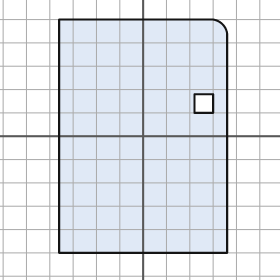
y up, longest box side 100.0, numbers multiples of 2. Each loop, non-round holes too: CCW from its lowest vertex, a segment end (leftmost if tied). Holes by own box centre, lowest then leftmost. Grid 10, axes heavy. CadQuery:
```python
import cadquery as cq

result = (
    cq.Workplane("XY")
    .moveTo(-36.0, -50.0)
    .lineTo(36.0, -50.0)
    .lineTo(36.0, 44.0)
    .threePointArc((34.0, 48.0), (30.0, 50.0))
    .lineTo(-36.0, 50.0)
    .close()
    .moveTo(22.0, 10.0)
    .lineTo(30.0, 10.0)
    .lineTo(30.0, 18.0)
    .lineTo(22.0, 18.0)
    .close()
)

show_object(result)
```